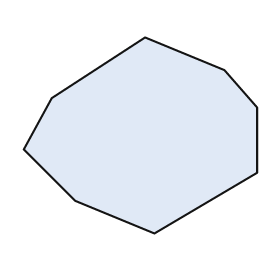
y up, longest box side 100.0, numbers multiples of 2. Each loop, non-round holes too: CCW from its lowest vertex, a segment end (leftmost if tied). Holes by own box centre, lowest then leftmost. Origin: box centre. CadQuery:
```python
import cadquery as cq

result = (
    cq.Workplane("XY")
    .moveTo(6.0, -42.0)
    .lineTo(50.0, -16.0)
    .lineTo(50.0, 12.0)
    .lineTo(36.0, 28.0)
    .lineTo(2.0, 42.0)
    .lineTo(-38.0, 16.0)
    .lineTo(-50.0, -6.0)
    .lineTo(-28.0, -28.0)
    .close()
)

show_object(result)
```